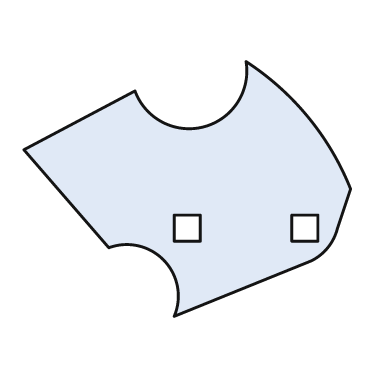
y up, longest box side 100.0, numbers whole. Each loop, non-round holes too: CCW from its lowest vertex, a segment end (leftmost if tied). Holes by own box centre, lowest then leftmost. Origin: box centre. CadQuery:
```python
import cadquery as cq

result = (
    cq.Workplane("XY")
    .moveTo(-4.0, -39.0)
    .lineTo(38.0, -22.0)
    .threePointArc((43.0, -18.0), (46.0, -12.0))
    .lineTo(50.0, 0.0)
    .threePointArc((37.0, 22.0), (18.0, 39.0))
    .threePointArc((5.0, 19.0), (-16.0, 30.0))
    .lineTo(-50.0, 12.0)
    .lineTo(-24.0, -18.0)
    .threePointArc((-7.0, -22.0), (-4.0, -39.0))
    .close()
    .moveTo(-4.0, -16.0)
    .lineTo(4.0, -16.0)
    .lineTo(4.0, -8.0)
    .lineTo(-4.0, -8.0)
    .close()
    .moveTo(32.0, -16.0)
    .lineTo(40.0, -16.0)
    .lineTo(40.0, -8.0)
    .lineTo(32.0, -8.0)
    .close()
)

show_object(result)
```